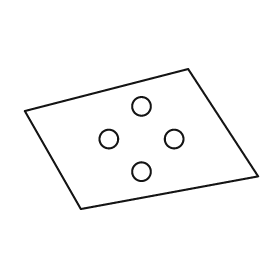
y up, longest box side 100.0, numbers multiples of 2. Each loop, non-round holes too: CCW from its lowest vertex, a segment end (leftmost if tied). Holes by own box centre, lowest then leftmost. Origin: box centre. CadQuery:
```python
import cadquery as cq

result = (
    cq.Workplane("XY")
    .moveTo(-26.0, -30.0)
    .lineTo(50.0, -16.0)
    .lineTo(20.0, 30.0)
    .lineTo(-50.0, 12.0)
    .close()
    .moveTo(0.0, -14.0)
    .circle(4.0)
    .moveTo(-14.0, 0.0)
    .circle(4.0)
    .moveTo(14.0, 0.0)
    .circle(4.0)
    .moveTo(0.0, 14.0)
    .circle(4.0)
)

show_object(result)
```